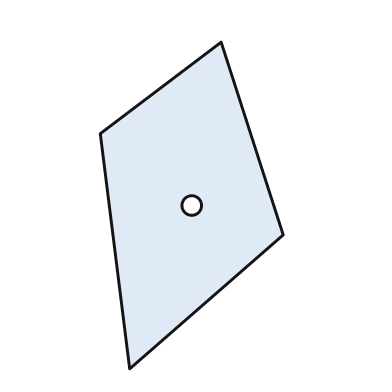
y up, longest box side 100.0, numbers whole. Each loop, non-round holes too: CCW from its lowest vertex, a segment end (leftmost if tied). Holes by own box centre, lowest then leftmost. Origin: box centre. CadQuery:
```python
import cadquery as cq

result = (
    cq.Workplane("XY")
    .moveTo(-19.0, -50.0)
    .lineTo(28.0, -9.0)
    .lineTo(9.0, 50.0)
    .lineTo(-28.0, 22.0)
    .close()
    .moveTo(0.0, 0.0)
    .circle(3.0)
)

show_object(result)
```